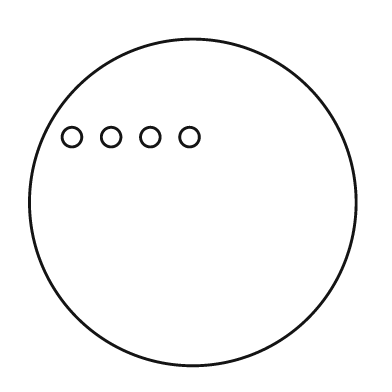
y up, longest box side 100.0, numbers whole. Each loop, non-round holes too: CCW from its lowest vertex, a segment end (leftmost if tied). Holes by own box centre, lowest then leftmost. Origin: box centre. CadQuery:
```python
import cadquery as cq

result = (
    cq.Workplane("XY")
    .moveTo(0.0, 0.0)
    .circle(50.0)
    .moveTo(-37.0, 20.0)
    .circle(3.0)
    .moveTo(-25.0, 20.0)
    .circle(3.0)
    .moveTo(-13.0, 20.0)
    .circle(3.0)
    .moveTo(-1.0, 20.0)
    .circle(3.0)
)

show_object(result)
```